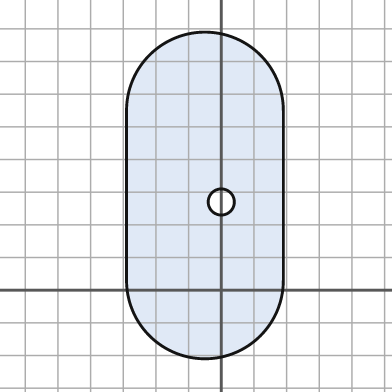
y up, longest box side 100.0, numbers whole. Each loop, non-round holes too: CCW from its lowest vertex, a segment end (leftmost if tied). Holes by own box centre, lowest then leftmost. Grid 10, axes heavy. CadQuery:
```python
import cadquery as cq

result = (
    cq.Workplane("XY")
    .moveTo(-29.0, 3.0)
    .threePointArc((-5.0, -21.0), (19.0, 3.0))
    .lineTo(19.0, 55.0)
    .threePointArc((-5.0, 79.0), (-29.0, 55.0))
    .close()
    .moveTo(0.0, 27.0)
    .circle(4.0)
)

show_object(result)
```